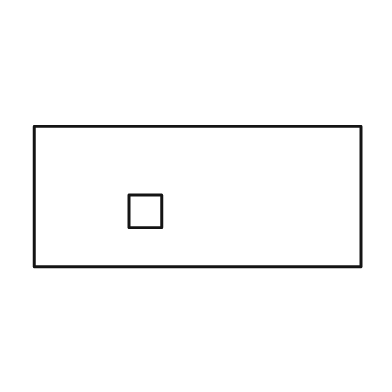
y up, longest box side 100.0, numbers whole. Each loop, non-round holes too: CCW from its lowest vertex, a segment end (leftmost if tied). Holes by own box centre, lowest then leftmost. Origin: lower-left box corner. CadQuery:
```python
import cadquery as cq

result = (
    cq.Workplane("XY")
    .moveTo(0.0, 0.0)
    .lineTo(100.0, 0.0)
    .lineTo(100.0, 43.0)
    .lineTo(0.0, 43.0)
    .close()
    .moveTo(29.0, 12.0)
    .lineTo(39.0, 12.0)
    .lineTo(39.0, 22.0)
    .lineTo(29.0, 22.0)
    .close()
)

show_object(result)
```